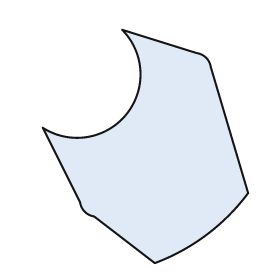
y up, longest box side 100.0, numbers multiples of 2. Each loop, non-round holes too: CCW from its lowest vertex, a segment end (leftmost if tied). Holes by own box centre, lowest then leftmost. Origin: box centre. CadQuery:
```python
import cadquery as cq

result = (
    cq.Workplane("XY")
    .moveTo(4.0, -50.0)
    .threePointArc((26.0, -38.0), (44.0, -20.0))
    .lineTo(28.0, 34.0)
    .threePointArc((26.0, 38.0), (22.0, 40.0))
    .lineTo(-10.0, 50.0)
    .threePointArc((-8.0, 14.0), (-44.0, 8.0))
    .lineTo(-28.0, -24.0)
    .threePointArc((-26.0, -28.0), (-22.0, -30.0))
    .close()
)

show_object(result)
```